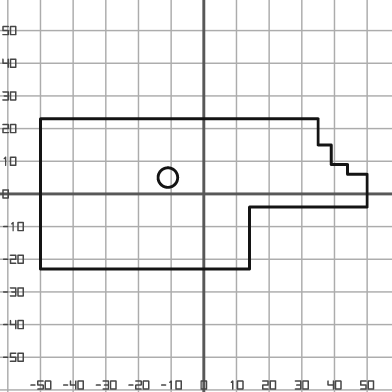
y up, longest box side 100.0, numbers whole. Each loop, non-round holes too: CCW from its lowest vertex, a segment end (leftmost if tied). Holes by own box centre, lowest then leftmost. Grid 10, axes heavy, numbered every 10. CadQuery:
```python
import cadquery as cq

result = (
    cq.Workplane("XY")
    .moveTo(-50.0, -23.0)
    .lineTo(14.0, -23.0)
    .lineTo(14.0, -4.0)
    .lineTo(50.0, -4.0)
    .lineTo(50.0, 6.0)
    .lineTo(44.0, 6.0)
    .lineTo(44.0, 9.0)
    .lineTo(39.0, 9.0)
    .lineTo(39.0, 15.0)
    .lineTo(35.0, 15.0)
    .lineTo(35.0, 23.0)
    .lineTo(-50.0, 23.0)
    .close()
    .moveTo(-11.0, 5.0)
    .circle(3.0)
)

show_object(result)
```